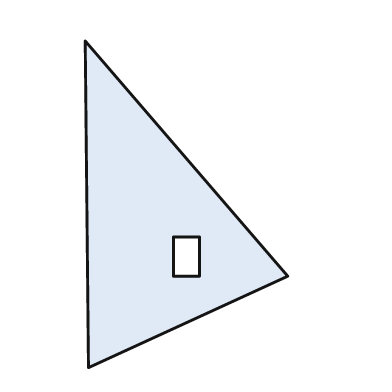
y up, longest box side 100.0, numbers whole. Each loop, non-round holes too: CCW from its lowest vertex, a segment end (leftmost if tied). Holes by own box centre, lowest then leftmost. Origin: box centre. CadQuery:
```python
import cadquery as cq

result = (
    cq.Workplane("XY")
    .moveTo(-30.0, -50.0)
    .lineTo(31.0, -22.0)
    .lineTo(-31.0, 50.0)
    .close()
    .moveTo(-4.0, -22.0)
    .lineTo(4.0, -22.0)
    .lineTo(4.0, -10.0)
    .lineTo(-4.0, -10.0)
    .close()
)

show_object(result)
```